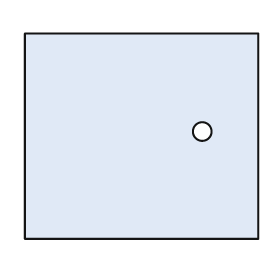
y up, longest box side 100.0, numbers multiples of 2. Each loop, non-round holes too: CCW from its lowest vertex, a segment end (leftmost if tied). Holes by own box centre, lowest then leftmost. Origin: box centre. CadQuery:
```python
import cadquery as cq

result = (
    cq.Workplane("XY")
    .moveTo(-50.0, -44.0)
    .lineTo(50.0, -44.0)
    .lineTo(50.0, 44.0)
    .lineTo(-50.0, 44.0)
    .close()
    .moveTo(26.0, 2.0)
    .circle(4.0)
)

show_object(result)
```